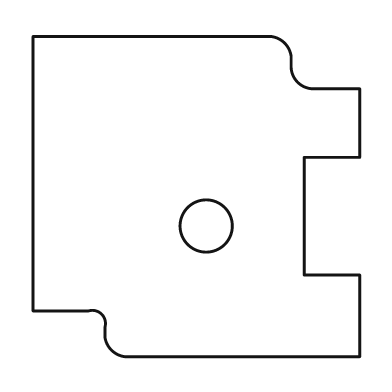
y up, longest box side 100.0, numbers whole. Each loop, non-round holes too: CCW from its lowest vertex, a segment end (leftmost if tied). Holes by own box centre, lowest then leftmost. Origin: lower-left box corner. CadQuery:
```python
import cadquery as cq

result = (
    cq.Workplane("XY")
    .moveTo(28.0, 0.0)
    .lineTo(100.0, 0.0)
    .lineTo(100.0, 25.0)
    .lineTo(83.0, 25.0)
    .lineTo(83.0, 61.0)
    .lineTo(100.0, 61.0)
    .lineTo(100.0, 82.0)
    .lineTo(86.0, 82.0)
    .threePointArc((81.0, 84.0), (79.0, 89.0))
    .lineTo(79.0, 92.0)
    .threePointArc((77.0, 96.0), (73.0, 98.0))
    .lineTo(0.0, 98.0)
    .lineTo(0.0, 14.0)
    .lineTo(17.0, 14.0)
    .threePointArc((21.0, 13.0), (22.0, 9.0))
    .lineTo(22.0, 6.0)
    .threePointArc((24.0, 2.0), (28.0, 0.0))
    .close()
    .moveTo(53.0, 40.0)
    .circle(8.0)
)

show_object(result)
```